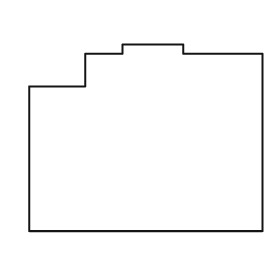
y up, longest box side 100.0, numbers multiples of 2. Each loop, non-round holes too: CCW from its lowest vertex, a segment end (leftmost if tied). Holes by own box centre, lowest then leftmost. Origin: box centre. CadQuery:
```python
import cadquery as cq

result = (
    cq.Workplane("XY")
    .moveTo(-50.0, -40.0)
    .lineTo(50.0, -40.0)
    .lineTo(50.0, 36.0)
    .lineTo(16.0, 36.0)
    .lineTo(16.0, 40.0)
    .lineTo(-10.0, 40.0)
    .lineTo(-10.0, 36.0)
    .lineTo(-26.0, 36.0)
    .lineTo(-26.0, 22.0)
    .lineTo(-50.0, 22.0)
    .close()
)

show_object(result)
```